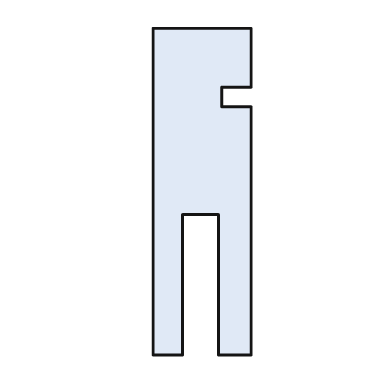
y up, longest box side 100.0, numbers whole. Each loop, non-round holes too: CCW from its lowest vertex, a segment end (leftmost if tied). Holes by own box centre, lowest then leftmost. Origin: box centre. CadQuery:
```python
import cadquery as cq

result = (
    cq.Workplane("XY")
    .moveTo(-15.0, -50.0)
    .lineTo(-6.0, -50.0)
    .lineTo(-6.0, -7.0)
    .lineTo(5.0, -7.0)
    .lineTo(5.0, -50.0)
    .lineTo(15.0, -50.0)
    .lineTo(15.0, 26.0)
    .lineTo(6.0, 26.0)
    .lineTo(6.0, 32.0)
    .lineTo(15.0, 32.0)
    .lineTo(15.0, 50.0)
    .lineTo(-15.0, 50.0)
    .close()
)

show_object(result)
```